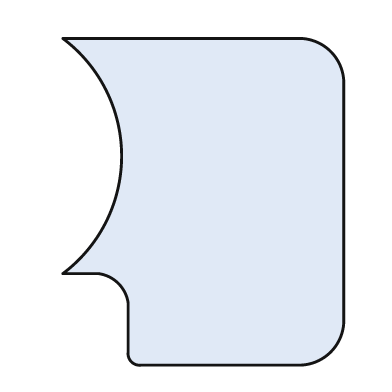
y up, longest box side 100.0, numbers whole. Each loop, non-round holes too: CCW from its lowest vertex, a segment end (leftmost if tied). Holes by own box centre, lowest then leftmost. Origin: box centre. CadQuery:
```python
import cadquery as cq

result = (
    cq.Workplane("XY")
    .moveTo(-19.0, -50.0)
    .lineTo(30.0, -50.0)
    .threePointArc((39.0, -46.0), (43.0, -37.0))
    .lineTo(43.0, 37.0)
    .threePointArc((39.0, 46.0), (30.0, 50.0))
    .lineTo(-43.0, 50.0)
    .threePointArc((-25.0, 14.0), (-43.0, -22.0))
    .lineTo(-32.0, -22.0)
    .threePointArc((-26.0, -25.0), (-23.0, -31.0))
    .lineTo(-23.0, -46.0)
    .threePointArc((-22.0, -49.0), (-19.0, -50.0))
    .close()
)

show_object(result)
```